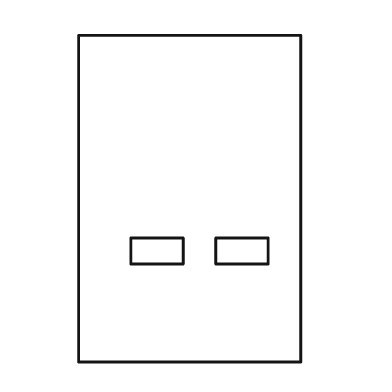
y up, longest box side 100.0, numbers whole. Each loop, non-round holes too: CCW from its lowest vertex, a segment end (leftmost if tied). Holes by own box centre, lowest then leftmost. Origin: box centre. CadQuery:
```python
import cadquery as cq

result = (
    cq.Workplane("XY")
    .moveTo(-34.0, -50.0)
    .lineTo(34.0, -50.0)
    .lineTo(34.0, 50.0)
    .lineTo(-34.0, 50.0)
    .close()
    .moveTo(-18.0, -20.0)
    .lineTo(-2.0, -20.0)
    .lineTo(-2.0, -12.0)
    .lineTo(-18.0, -12.0)
    .close()
    .moveTo(8.0, -20.0)
    .lineTo(24.0, -20.0)
    .lineTo(24.0, -12.0)
    .lineTo(8.0, -12.0)
    .close()
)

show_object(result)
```